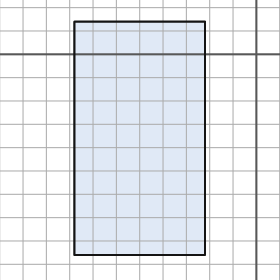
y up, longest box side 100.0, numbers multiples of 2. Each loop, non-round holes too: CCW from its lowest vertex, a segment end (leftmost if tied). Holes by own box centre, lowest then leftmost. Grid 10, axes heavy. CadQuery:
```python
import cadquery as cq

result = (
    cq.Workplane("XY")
    .moveTo(-78.0, -86.0)
    .lineTo(-22.0, -86.0)
    .lineTo(-22.0, 14.0)
    .lineTo(-78.0, 14.0)
    .close()
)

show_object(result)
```